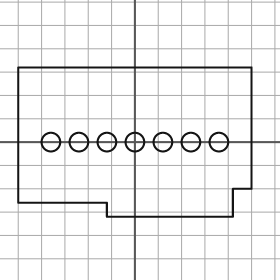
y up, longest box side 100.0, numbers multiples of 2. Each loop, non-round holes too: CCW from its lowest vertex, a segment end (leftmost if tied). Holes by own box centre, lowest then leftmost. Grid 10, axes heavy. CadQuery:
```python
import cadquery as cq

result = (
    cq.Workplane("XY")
    .moveTo(-12.0, -32.0)
    .lineTo(42.0, -32.0)
    .lineTo(42.0, -20.0)
    .lineTo(50.0, -20.0)
    .lineTo(50.0, 32.0)
    .lineTo(-50.0, 32.0)
    .lineTo(-50.0, -26.0)
    .lineTo(-12.0, -26.0)
    .close()
    .moveTo(-36.0, 0.0)
    .circle(4.0)
    .moveTo(-24.0, 0.0)
    .circle(4.0)
    .moveTo(-12.0, 0.0)
    .circle(4.0)
    .moveTo(0.0, 0.0)
    .circle(4.0)
    .moveTo(12.0, 0.0)
    .circle(4.0)
    .moveTo(24.0, 0.0)
    .circle(4.0)
    .moveTo(36.0, 0.0)
    .circle(4.0)
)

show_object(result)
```